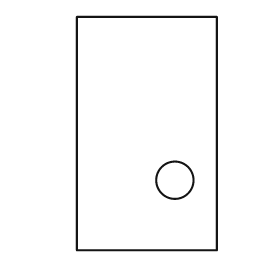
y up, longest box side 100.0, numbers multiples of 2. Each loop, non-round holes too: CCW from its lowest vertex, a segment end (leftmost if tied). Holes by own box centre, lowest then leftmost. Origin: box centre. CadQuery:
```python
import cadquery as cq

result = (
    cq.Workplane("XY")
    .moveTo(-30.0, -50.0)
    .lineTo(30.0, -50.0)
    .lineTo(30.0, 50.0)
    .lineTo(-30.0, 50.0)
    .close()
    .moveTo(12.0, -20.0)
    .circle(8.0)
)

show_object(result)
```